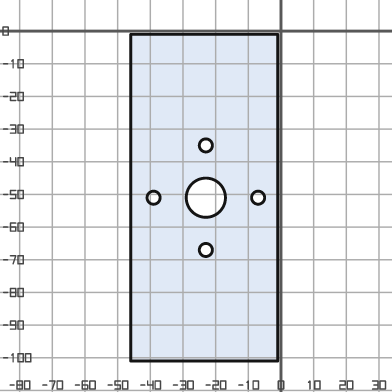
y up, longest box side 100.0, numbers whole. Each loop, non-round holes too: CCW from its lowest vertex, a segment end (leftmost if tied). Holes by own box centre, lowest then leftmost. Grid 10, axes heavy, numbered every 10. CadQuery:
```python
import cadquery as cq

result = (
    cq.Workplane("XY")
    .moveTo(-46.0, -101.0)
    .lineTo(-1.0, -101.0)
    .lineTo(-1.0, -1.0)
    .lineTo(-46.0, -1.0)
    .close()
    .moveTo(-23.0, -67.0)
    .circle(2.0)
    .moveTo(-39.0, -51.0)
    .circle(2.0)
    .moveTo(-23.0, -51.0)
    .circle(6.0)
    .moveTo(-7.0, -51.0)
    .circle(2.0)
    .moveTo(-23.0, -35.0)
    .circle(2.0)
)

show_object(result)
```